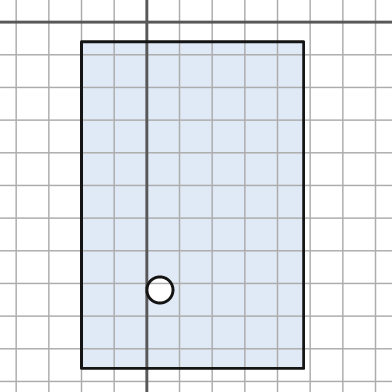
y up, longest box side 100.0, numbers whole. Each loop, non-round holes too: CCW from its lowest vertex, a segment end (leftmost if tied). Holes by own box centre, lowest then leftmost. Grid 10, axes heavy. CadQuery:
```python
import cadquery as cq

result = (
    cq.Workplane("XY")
    .moveTo(-20.0, -106.0)
    .lineTo(48.0, -106.0)
    .lineTo(48.0, -6.0)
    .lineTo(-20.0, -6.0)
    .close()
    .moveTo(4.0, -82.0)
    .circle(4.0)
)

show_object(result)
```